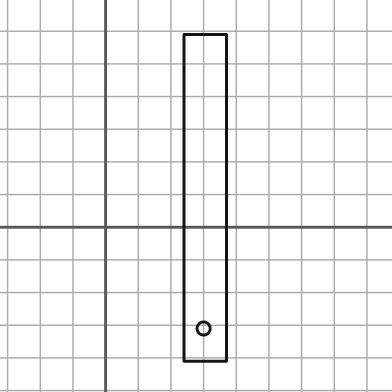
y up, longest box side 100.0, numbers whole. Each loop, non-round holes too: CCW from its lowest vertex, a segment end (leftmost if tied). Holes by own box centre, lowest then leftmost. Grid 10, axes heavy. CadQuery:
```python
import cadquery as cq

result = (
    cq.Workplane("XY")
    .moveTo(24.0, -41.0)
    .lineTo(37.0, -41.0)
    .lineTo(37.0, 59.0)
    .lineTo(24.0, 59.0)
    .close()
    .moveTo(30.0, -31.0)
    .circle(2.0)
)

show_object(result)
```